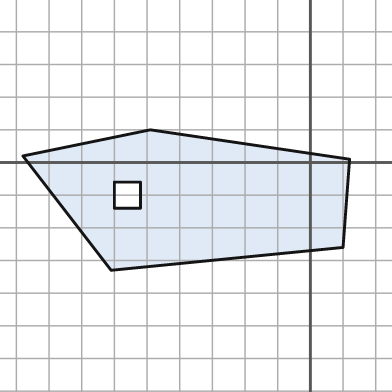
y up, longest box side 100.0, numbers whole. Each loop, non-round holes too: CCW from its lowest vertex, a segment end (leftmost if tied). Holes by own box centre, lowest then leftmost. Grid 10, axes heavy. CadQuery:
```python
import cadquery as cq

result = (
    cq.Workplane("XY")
    .moveTo(-61.0, -33.0)
    .lineTo(10.0, -26.0)
    .lineTo(12.0, 1.0)
    .lineTo(-49.0, 10.0)
    .lineTo(-88.0, 2.0)
    .close()
    .moveTo(-60.0, -14.0)
    .lineTo(-52.0, -14.0)
    .lineTo(-52.0, -6.0)
    .lineTo(-60.0, -6.0)
    .close()
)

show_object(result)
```